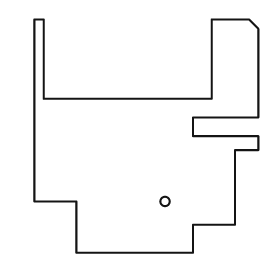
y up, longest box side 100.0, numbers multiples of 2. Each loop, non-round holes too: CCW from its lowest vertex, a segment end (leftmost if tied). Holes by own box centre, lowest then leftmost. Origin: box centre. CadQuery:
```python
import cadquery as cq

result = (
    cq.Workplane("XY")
    .moveTo(-30.0, -50.0)
    .lineTo(20.0, -50.0)
    .lineTo(20.0, -38.0)
    .lineTo(38.0, -38.0)
    .lineTo(38.0, -6.0)
    .lineTo(48.0, -6.0)
    .lineTo(48.0, 0.0)
    .lineTo(20.0, 0.0)
    .lineTo(20.0, 8.0)
    .lineTo(48.0, 8.0)
    .lineTo(48.0, 46.0)
    .lineTo(44.0, 50.0)
    .lineTo(28.0, 50.0)
    .lineTo(28.0, 16.0)
    .lineTo(-44.0, 16.0)
    .lineTo(-44.0, 50.0)
    .lineTo(-48.0, 50.0)
    .lineTo(-48.0, -28.0)
    .lineTo(-30.0, -28.0)
    .close()
    .moveTo(8.0, -28.0)
    .circle(2.0)
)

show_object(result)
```